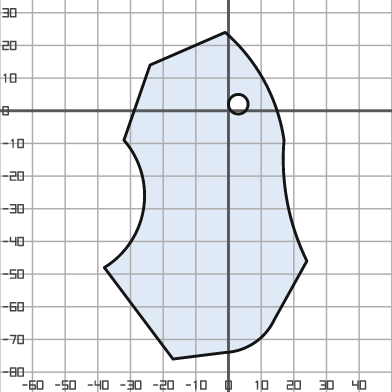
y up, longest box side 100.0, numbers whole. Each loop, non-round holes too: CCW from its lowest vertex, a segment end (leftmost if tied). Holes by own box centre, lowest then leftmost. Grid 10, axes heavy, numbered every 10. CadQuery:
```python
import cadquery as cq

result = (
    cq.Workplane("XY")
    .moveTo(-17.0, -76.0)
    .lineTo(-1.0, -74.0)
    .threePointArc((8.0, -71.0), (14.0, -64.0))
    .lineTo(24.0, -46.0)
    .threePointArc((18.0, -28.0), (17.0, -9.0))
    .threePointArc((11.0, 9.0), (-1.0, 24.0))
    .lineTo(-24.0, 14.0)
    .lineTo(-32.0, -9.0)
    .threePointArc((-26.0, -30.0), (-38.0, -48.0))
    .close()
    .moveTo(3.0, 2.0)
    .circle(3.0)
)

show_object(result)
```